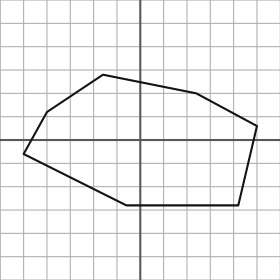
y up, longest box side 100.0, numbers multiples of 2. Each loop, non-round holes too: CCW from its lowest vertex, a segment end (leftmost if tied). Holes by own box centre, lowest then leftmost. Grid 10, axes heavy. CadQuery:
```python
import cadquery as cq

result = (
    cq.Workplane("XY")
    .moveTo(-6.0, -28.0)
    .lineTo(42.0, -28.0)
    .lineTo(50.0, 6.0)
    .lineTo(24.0, 20.0)
    .lineTo(-16.0, 28.0)
    .lineTo(-40.0, 12.0)
    .lineTo(-50.0, -6.0)
    .close()
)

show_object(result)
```